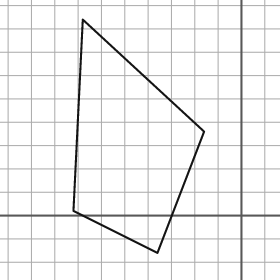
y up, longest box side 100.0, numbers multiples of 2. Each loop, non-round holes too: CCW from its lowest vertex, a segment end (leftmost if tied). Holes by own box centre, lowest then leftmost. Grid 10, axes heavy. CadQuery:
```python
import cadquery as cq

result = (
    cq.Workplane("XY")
    .moveTo(-36.0, -16.0)
    .lineTo(-16.0, 36.0)
    .lineTo(-68.0, 84.0)
    .lineTo(-72.0, 2.0)
    .close()
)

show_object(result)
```